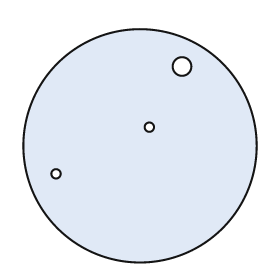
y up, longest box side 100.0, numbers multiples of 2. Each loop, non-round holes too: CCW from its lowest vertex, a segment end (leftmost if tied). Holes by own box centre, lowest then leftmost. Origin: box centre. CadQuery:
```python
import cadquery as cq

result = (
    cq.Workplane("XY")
    .moveTo(0.0, 0.0)
    .circle(50.0)
    .moveTo(-36.0, -12.0)
    .circle(2.0)
    .moveTo(4.0, 8.0)
    .circle(2.0)
    .moveTo(18.0, 34.0)
    .circle(4.0)
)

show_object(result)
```